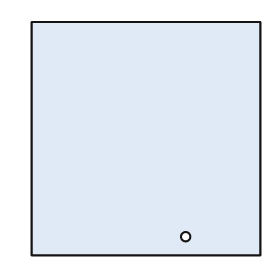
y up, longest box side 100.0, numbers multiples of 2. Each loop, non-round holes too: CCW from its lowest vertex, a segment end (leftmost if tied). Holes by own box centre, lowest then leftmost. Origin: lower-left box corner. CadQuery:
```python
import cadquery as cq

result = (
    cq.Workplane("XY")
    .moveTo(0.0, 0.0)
    .lineTo(98.0, 0.0)
    .lineTo(98.0, 100.0)
    .lineTo(0.0, 100.0)
    .close()
    .moveTo(66.0, 8.0)
    .circle(2.0)
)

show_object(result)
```